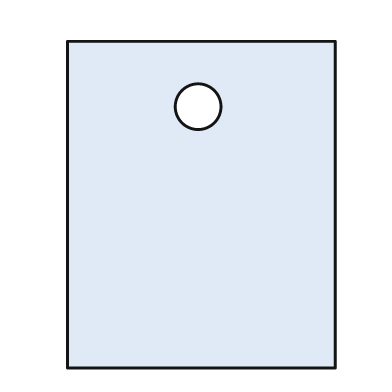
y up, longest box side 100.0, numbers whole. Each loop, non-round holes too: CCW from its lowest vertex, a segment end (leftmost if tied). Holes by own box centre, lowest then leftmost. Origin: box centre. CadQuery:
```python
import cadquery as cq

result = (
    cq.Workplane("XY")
    .moveTo(-41.0, -50.0)
    .lineTo(41.0, -50.0)
    .lineTo(41.0, 50.0)
    .lineTo(-41.0, 50.0)
    .close()
    .moveTo(-1.0, 30.0)
    .circle(7.0)
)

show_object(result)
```